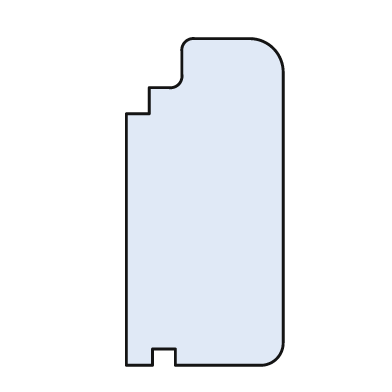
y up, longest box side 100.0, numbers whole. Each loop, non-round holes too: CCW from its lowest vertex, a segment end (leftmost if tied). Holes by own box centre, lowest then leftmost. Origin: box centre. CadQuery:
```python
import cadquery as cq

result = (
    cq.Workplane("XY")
    .moveTo(-24.0, -50.0)
    .lineTo(-16.0, -50.0)
    .lineTo(-16.0, -45.0)
    .lineTo(-9.0, -45.0)
    .lineTo(-9.0, -50.0)
    .lineTo(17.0, -50.0)
    .threePointArc((22.0, -48.0), (24.0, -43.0))
    .lineTo(24.0, 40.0)
    .threePointArc((21.0, 47.0), (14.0, 50.0))
    .lineTo(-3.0, 50.0)
    .threePointArc((-6.0, 49.0), (-7.0, 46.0))
    .lineTo(-7.0, 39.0)
    .threePointArc((-8.0, 36.0), (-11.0, 35.0))
    .lineTo(-17.0, 35.0)
    .lineTo(-17.0, 27.0)
    .lineTo(-24.0, 27.0)
    .close()
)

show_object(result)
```